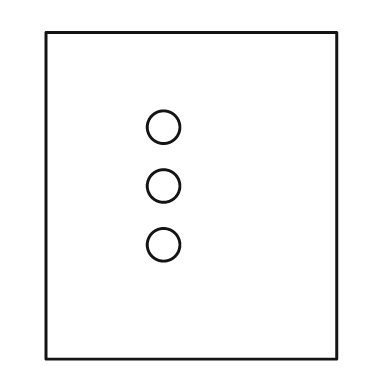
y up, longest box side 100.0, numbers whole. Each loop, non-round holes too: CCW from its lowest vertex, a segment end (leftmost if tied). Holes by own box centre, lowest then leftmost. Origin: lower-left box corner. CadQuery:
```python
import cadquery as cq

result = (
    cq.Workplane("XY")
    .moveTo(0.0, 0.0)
    .lineTo(89.0, 0.0)
    .lineTo(89.0, 100.0)
    .lineTo(0.0, 100.0)
    .close()
    .moveTo(36.0, 35.0)
    .circle(5.0)
    .moveTo(36.0, 53.0)
    .circle(5.0)
    .moveTo(36.0, 71.0)
    .circle(5.0)
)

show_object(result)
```